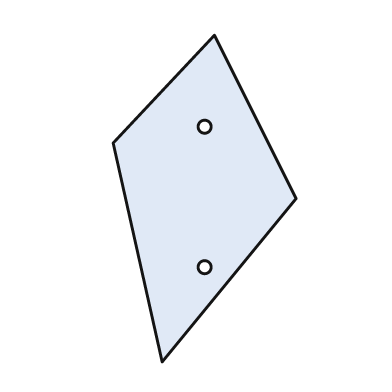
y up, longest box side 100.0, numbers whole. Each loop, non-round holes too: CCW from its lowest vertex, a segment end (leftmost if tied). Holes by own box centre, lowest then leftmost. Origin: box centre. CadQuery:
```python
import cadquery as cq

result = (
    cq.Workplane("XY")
    .moveTo(-13.0, -50.0)
    .lineTo(28.0, 0.0)
    .lineTo(3.0, 50.0)
    .lineTo(-28.0, 17.0)
    .close()
    .moveTo(0.0, -21.0)
    .circle(2.0)
    .moveTo(0.0, 22.0)
    .circle(2.0)
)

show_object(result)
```